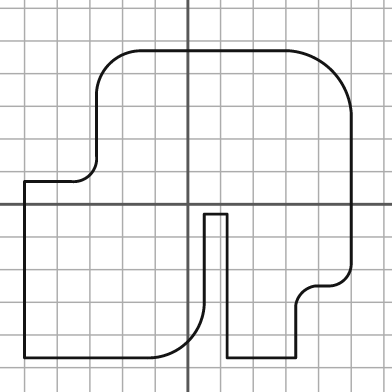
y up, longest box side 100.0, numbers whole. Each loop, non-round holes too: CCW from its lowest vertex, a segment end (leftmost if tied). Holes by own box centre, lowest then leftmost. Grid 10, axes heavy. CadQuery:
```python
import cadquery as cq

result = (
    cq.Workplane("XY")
    .moveTo(-50.0, -47.0)
    .lineTo(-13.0, -47.0)
    .threePointArc((0.0, -42.0), (5.0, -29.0))
    .lineTo(5.0, -3.0)
    .lineTo(12.0, -3.0)
    .lineTo(12.0, -47.0)
    .lineTo(33.0, -47.0)
    .lineTo(33.0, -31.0)
    .threePointArc((35.0, -27.0), (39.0, -25.0))
    .lineTo(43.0, -25.0)
    .threePointArc((48.0, -23.0), (50.0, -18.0))
    .lineTo(50.0, 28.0)
    .threePointArc((44.0, 41.0), (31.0, 47.0))
    .lineTo(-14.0, 47.0)
    .threePointArc((-24.0, 43.0), (-28.0, 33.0))
    .lineTo(-28.0, 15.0)
    .threePointArc((-30.0, 9.0), (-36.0, 7.0))
    .lineTo(-50.0, 7.0)
    .close()
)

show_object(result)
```